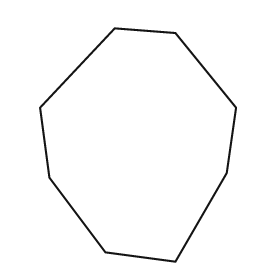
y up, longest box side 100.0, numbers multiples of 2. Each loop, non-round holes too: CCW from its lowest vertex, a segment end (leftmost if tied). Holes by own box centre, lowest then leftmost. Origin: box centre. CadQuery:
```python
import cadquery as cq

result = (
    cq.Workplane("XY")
    .moveTo(16.0, -50.0)
    .lineTo(38.0, -12.0)
    .lineTo(42.0, 16.0)
    .lineTo(16.0, 48.0)
    .lineTo(-10.0, 50.0)
    .lineTo(-42.0, 16.0)
    .lineTo(-38.0, -14.0)
    .lineTo(-14.0, -46.0)
    .close()
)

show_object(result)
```